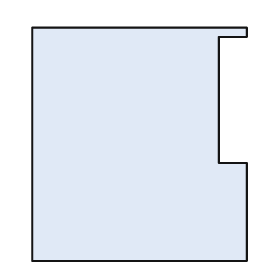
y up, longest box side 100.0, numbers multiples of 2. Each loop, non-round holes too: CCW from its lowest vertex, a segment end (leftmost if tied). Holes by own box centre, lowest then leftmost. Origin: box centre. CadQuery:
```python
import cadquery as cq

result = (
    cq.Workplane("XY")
    .moveTo(-46.0, -50.0)
    .lineTo(46.0, -50.0)
    .lineTo(46.0, -8.0)
    .lineTo(34.0, -8.0)
    .lineTo(34.0, 46.0)
    .lineTo(46.0, 46.0)
    .lineTo(46.0, 50.0)
    .lineTo(-46.0, 50.0)
    .close()
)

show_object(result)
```